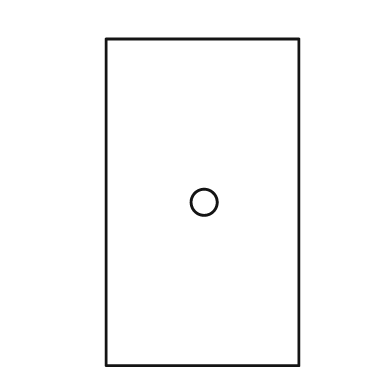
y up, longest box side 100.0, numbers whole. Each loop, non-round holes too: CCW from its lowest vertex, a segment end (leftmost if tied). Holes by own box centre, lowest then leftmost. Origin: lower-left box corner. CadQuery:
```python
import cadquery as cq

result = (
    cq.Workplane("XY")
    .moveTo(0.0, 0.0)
    .lineTo(59.0, 0.0)
    .lineTo(59.0, 100.0)
    .lineTo(0.0, 100.0)
    .close()
    .moveTo(30.0, 50.0)
    .circle(4.0)
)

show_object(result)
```